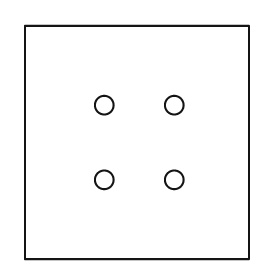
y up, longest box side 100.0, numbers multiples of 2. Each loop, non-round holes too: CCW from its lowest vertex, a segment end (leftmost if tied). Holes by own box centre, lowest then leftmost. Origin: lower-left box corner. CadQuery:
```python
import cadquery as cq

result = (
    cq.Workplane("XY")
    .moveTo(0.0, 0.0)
    .lineTo(96.0, 0.0)
    .lineTo(96.0, 100.0)
    .lineTo(0.0, 100.0)
    .close()
    .moveTo(34.0, 34.0)
    .circle(4.0)
    .moveTo(64.0, 34.0)
    .circle(4.0)
    .moveTo(34.0, 66.0)
    .circle(4.0)
    .moveTo(64.0, 66.0)
    .circle(4.0)
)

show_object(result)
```